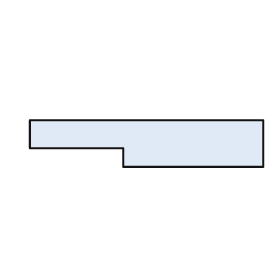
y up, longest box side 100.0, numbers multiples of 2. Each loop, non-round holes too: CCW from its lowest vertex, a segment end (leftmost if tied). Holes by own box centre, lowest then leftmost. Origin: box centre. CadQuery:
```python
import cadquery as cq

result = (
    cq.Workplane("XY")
    .moveTo(-10.0, -10.0)
    .lineTo(50.0, -10.0)
    .lineTo(50.0, 10.0)
    .lineTo(-50.0, 10.0)
    .lineTo(-50.0, -2.0)
    .lineTo(-10.0, -2.0)
    .close()
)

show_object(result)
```